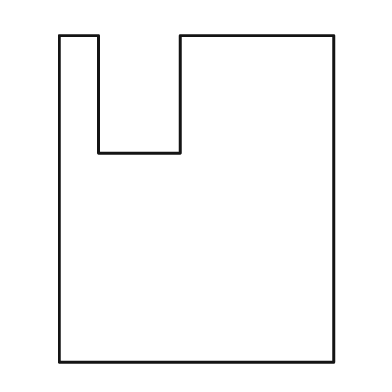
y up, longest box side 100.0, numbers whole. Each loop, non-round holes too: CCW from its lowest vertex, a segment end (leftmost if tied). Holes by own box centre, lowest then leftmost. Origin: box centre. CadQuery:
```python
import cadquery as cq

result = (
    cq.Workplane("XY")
    .moveTo(-42.0, -50.0)
    .lineTo(42.0, -50.0)
    .lineTo(42.0, 50.0)
    .lineTo(-5.0, 50.0)
    .lineTo(-5.0, 14.0)
    .lineTo(-30.0, 14.0)
    .lineTo(-30.0, 50.0)
    .lineTo(-42.0, 50.0)
    .close()
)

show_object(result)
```